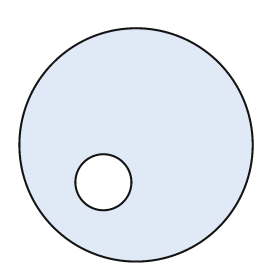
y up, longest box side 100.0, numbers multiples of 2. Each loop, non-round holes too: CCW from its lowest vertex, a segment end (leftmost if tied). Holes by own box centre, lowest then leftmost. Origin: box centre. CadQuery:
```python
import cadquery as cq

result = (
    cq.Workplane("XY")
    .moveTo(0.0, 0.0)
    .circle(50.0)
    .moveTo(-14.0, -16.0)
    .circle(12.0)
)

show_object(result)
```